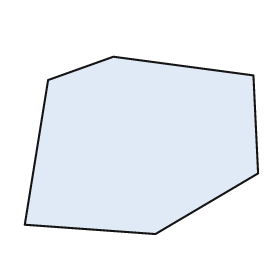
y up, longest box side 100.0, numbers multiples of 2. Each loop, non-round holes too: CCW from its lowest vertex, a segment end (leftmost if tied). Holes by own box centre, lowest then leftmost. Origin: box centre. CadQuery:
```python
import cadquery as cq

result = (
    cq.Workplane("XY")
    .moveTo(6.0, -38.0)
    .lineTo(50.0, -12.0)
    .lineTo(48.0, 30.0)
    .lineTo(-12.0, 38.0)
    .lineTo(-40.0, 28.0)
    .lineTo(-50.0, -34.0)
    .close()
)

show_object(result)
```